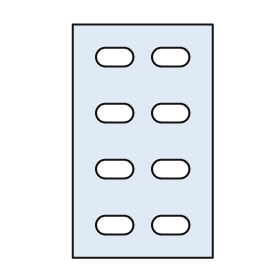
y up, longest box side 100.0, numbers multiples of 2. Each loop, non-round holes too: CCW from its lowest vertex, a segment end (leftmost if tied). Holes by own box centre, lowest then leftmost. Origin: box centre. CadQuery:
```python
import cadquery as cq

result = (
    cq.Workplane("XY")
    .moveTo(-30.0, -50.0)
    .lineTo(30.0, -50.0)
    .lineTo(30.0, 50.0)
    .lineTo(-30.0, 50.0)
    .close()
    .moveTo(-16.0, -40.0)
    .lineTo(-8.0, -40.0)
    .threePointArc((-4.0, -36.0), (-8.0, -32.0))
    .lineTo(-16.0, -32.0)
    .threePointArc((-20.0, -36.0), (-16.0, -40.0))
    .close()
    .moveTo(8.0, -40.0)
    .lineTo(16.0, -40.0)
    .threePointArc((20.0, -36.0), (16.0, -32.0))
    .lineTo(8.0, -32.0)
    .threePointArc((4.0, -36.0), (8.0, -40.0))
    .close()
    .moveTo(-16.0, -16.0)
    .lineTo(-8.0, -16.0)
    .threePointArc((-4.0, -12.0), (-8.0, -8.0))
    .lineTo(-16.0, -8.0)
    .threePointArc((-20.0, -12.0), (-16.0, -16.0))
    .close()
    .moveTo(8.0, -16.0)
    .lineTo(16.0, -16.0)
    .threePointArc((20.0, -12.0), (16.0, -8.0))
    .lineTo(8.0, -8.0)
    .threePointArc((4.0, -12.0), (8.0, -16.0))
    .close()
    .moveTo(-16.0, 8.0)
    .lineTo(-8.0, 8.0)
    .threePointArc((-4.0, 12.0), (-8.0, 16.0))
    .lineTo(-16.0, 16.0)
    .threePointArc((-20.0, 12.0), (-16.0, 8.0))
    .close()
    .moveTo(8.0, 8.0)
    .lineTo(16.0, 8.0)
    .threePointArc((20.0, 12.0), (16.0, 16.0))
    .lineTo(8.0, 16.0)
    .threePointArc((4.0, 12.0), (8.0, 8.0))
    .close()
    .moveTo(-16.0, 32.0)
    .lineTo(-8.0, 32.0)
    .threePointArc((-4.0, 36.0), (-8.0, 40.0))
    .lineTo(-16.0, 40.0)
    .threePointArc((-20.0, 36.0), (-16.0, 32.0))
    .close()
    .moveTo(8.0, 32.0)
    .lineTo(16.0, 32.0)
    .threePointArc((20.0, 36.0), (16.0, 40.0))
    .lineTo(8.0, 40.0)
    .threePointArc((4.0, 36.0), (8.0, 32.0))
    .close()
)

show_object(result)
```